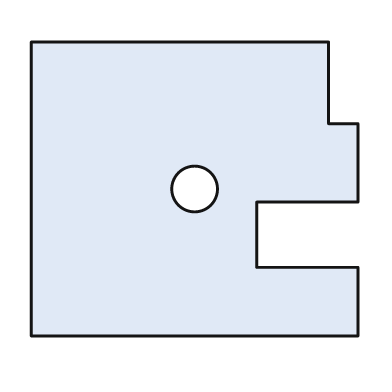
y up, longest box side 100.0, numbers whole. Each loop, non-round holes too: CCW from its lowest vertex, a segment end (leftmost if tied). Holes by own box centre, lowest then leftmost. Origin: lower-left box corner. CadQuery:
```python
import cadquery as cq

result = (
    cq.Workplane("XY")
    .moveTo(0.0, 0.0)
    .lineTo(100.0, 0.0)
    .lineTo(100.0, 21.0)
    .lineTo(69.0, 21.0)
    .lineTo(69.0, 41.0)
    .lineTo(100.0, 41.0)
    .lineTo(100.0, 65.0)
    .lineTo(91.0, 65.0)
    .lineTo(91.0, 90.0)
    .lineTo(0.0, 90.0)
    .close()
    .moveTo(50.0, 45.0)
    .circle(7.0)
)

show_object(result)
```